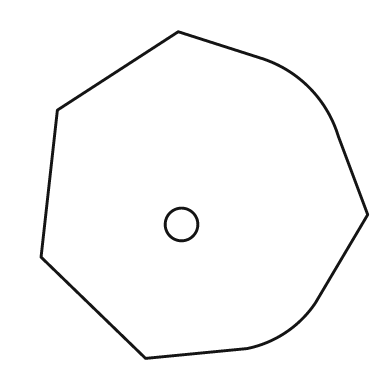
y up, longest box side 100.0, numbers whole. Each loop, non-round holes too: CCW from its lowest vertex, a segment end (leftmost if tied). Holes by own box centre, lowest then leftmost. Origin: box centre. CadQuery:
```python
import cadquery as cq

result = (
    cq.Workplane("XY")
    .moveTo(-18.0, -50.0)
    .lineTo(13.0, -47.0)
    .threePointArc((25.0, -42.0), (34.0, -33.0))
    .lineTo(50.0, -6.0)
    .lineTo(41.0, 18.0)
    .threePointArc((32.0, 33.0), (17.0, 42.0))
    .lineTo(-8.0, 50.0)
    .lineTo(-45.0, 26.0)
    .lineTo(-50.0, -19.0)
    .close()
    .moveTo(-7.0, -9.0)
    .circle(5.0)
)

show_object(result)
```